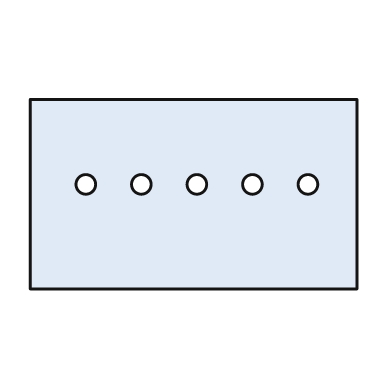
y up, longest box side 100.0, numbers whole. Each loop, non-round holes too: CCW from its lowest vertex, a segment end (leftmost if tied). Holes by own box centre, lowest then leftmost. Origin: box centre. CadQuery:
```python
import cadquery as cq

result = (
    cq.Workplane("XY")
    .moveTo(-50.0, -29.0)
    .lineTo(50.0, -29.0)
    .lineTo(50.0, 29.0)
    .lineTo(-50.0, 29.0)
    .close()
    .moveTo(-33.0, 3.0)
    .circle(3.0)
    .moveTo(-16.0, 3.0)
    .circle(3.0)
    .moveTo(1.0, 3.0)
    .circle(3.0)
    .moveTo(18.0, 3.0)
    .circle(3.0)
    .moveTo(35.0, 3.0)
    .circle(3.0)
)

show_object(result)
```